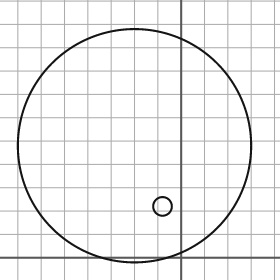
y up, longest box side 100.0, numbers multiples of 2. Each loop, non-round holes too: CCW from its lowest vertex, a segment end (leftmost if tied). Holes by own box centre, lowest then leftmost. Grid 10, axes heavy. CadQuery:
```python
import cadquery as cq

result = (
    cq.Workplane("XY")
    .moveTo(-20.0, 48.0)
    .circle(50.0)
    .moveTo(-8.0, 22.0)
    .circle(4.0)
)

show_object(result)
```